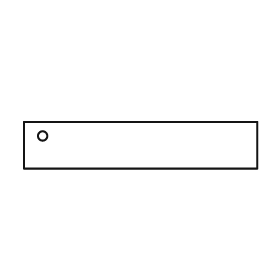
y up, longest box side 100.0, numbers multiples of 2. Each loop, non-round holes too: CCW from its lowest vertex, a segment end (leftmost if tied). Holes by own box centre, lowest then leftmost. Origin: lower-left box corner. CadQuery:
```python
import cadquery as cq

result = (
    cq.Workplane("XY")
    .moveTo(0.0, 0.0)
    .lineTo(100.0, 0.0)
    .lineTo(100.0, 20.0)
    .lineTo(0.0, 20.0)
    .close()
    .moveTo(8.0, 14.0)
    .circle(2.0)
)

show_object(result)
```